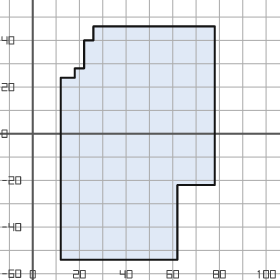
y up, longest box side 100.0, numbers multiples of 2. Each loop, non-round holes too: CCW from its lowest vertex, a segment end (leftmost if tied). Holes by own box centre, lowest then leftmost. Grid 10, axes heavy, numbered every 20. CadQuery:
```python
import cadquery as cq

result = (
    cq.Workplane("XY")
    .moveTo(12.0, -54.0)
    .lineTo(62.0, -54.0)
    .lineTo(62.0, -22.0)
    .lineTo(78.0, -22.0)
    .lineTo(78.0, 46.0)
    .lineTo(26.0, 46.0)
    .lineTo(26.0, 40.0)
    .lineTo(22.0, 40.0)
    .lineTo(22.0, 28.0)
    .lineTo(18.0, 28.0)
    .lineTo(18.0, 24.0)
    .lineTo(12.0, 24.0)
    .close()
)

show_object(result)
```